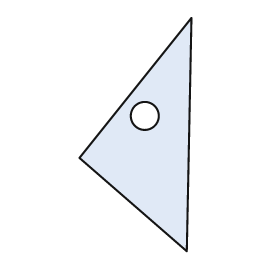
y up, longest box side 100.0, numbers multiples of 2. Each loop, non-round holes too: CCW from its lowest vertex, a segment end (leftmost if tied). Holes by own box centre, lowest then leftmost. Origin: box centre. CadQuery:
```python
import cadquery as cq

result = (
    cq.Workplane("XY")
    .moveTo(22.0, -50.0)
    .lineTo(24.0, 50.0)
    .lineTo(-24.0, -10.0)
    .close()
    .moveTo(4.0, 8.0)
    .circle(6.0)
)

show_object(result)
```